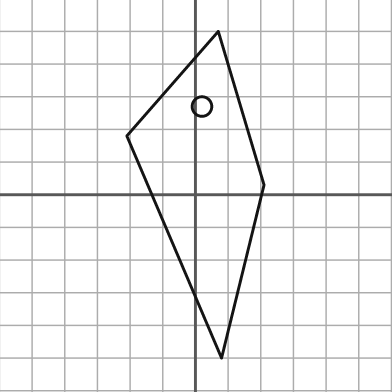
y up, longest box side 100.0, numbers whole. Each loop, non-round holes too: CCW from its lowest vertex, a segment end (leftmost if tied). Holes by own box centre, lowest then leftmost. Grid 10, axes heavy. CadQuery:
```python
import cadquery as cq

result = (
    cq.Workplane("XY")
    .moveTo(8.0, -50.0)
    .lineTo(21.0, 3.0)
    .lineTo(7.0, 50.0)
    .lineTo(-21.0, 18.0)
    .close()
    .moveTo(2.0, 27.0)
    .circle(3.0)
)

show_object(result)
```